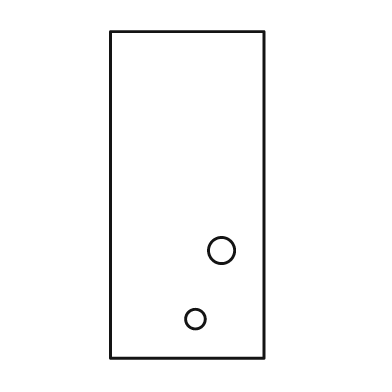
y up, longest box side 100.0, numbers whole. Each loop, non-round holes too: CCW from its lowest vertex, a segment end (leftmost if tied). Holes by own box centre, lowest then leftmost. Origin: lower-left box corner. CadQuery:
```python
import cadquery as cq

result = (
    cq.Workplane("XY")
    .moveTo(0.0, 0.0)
    .lineTo(47.0, 0.0)
    .lineTo(47.0, 100.0)
    .lineTo(0.0, 100.0)
    .close()
    .moveTo(26.0, 12.0)
    .circle(3.0)
    .moveTo(34.0, 33.0)
    .circle(4.0)
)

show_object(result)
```